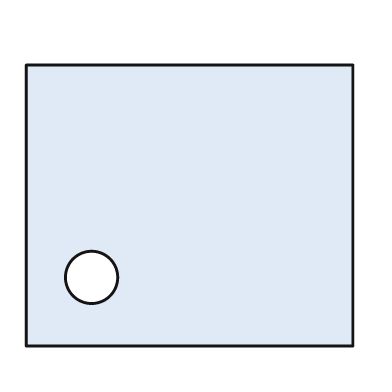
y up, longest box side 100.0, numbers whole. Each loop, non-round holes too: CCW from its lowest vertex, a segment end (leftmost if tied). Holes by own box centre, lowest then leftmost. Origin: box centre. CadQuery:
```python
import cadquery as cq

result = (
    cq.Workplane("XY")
    .moveTo(-50.0, -43.0)
    .lineTo(50.0, -43.0)
    .lineTo(50.0, 43.0)
    .lineTo(-50.0, 43.0)
    .close()
    .moveTo(-30.0, -22.0)
    .circle(8.0)
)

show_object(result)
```